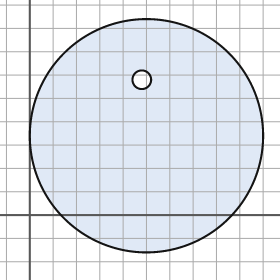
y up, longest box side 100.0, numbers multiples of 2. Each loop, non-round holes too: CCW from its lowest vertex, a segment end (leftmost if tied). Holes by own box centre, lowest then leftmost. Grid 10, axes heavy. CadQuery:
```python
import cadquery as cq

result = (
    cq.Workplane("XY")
    .moveTo(50.0, 34.0)
    .circle(50.0)
    .moveTo(48.0, 58.0)
    .circle(4.0)
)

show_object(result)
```